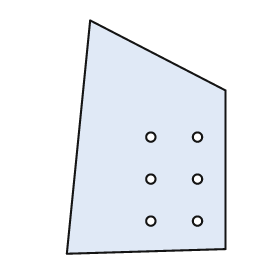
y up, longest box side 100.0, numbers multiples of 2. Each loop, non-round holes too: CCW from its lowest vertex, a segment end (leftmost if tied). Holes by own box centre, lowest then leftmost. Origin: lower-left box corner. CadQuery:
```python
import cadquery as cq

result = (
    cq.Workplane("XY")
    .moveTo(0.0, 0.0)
    .lineTo(68.0, 2.0)
    .lineTo(68.0, 70.0)
    .lineTo(10.0, 100.0)
    .close()
    .moveTo(36.0, 14.0)
    .circle(2.0)
    .moveTo(56.0, 14.0)
    .circle(2.0)
    .moveTo(36.0, 32.0)
    .circle(2.0)
    .moveTo(56.0, 32.0)
    .circle(2.0)
    .moveTo(36.0, 50.0)
    .circle(2.0)
    .moveTo(56.0, 50.0)
    .circle(2.0)
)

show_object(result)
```